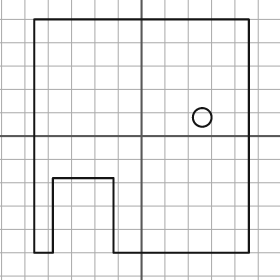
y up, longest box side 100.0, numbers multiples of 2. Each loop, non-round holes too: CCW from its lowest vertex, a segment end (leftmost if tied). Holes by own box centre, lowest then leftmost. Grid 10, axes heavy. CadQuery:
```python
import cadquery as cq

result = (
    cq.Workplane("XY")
    .moveTo(-46.0, -50.0)
    .lineTo(-38.0, -50.0)
    .lineTo(-38.0, -18.0)
    .lineTo(-12.0, -18.0)
    .lineTo(-12.0, -50.0)
    .lineTo(46.0, -50.0)
    .lineTo(46.0, 50.0)
    .lineTo(-46.0, 50.0)
    .close()
    .moveTo(26.0, 8.0)
    .circle(4.0)
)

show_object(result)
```